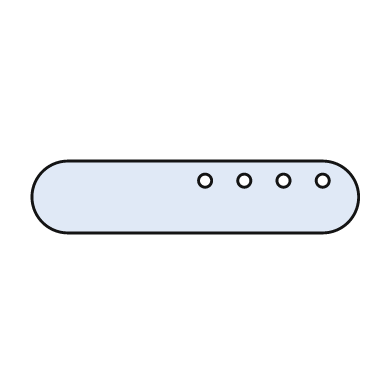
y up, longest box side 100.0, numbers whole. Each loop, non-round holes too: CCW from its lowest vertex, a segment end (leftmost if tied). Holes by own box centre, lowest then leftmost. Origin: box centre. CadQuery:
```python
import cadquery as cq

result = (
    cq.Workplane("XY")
    .moveTo(-39.0, -11.0)
    .lineTo(39.0, -11.0)
    .threePointArc((50.0, 0.0), (39.0, 11.0))
    .lineTo(-39.0, 11.0)
    .threePointArc((-50.0, 0.0), (-39.0, -11.0))
    .close()
    .moveTo(3.0, 5.0)
    .circle(2.0)
    .moveTo(15.0, 5.0)
    .circle(2.0)
    .moveTo(27.0, 5.0)
    .circle(2.0)
    .moveTo(39.0, 5.0)
    .circle(2.0)
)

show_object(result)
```